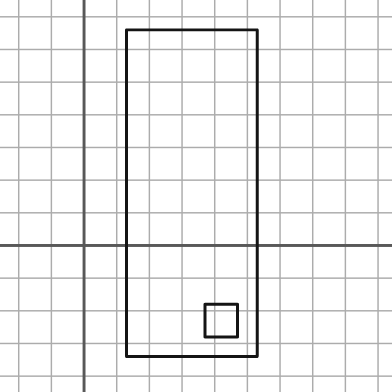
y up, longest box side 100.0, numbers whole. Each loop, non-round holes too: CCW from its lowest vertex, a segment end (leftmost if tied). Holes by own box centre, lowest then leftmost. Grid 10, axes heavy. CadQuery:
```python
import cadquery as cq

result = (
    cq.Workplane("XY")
    .moveTo(13.0, -34.0)
    .lineTo(53.0, -34.0)
    .lineTo(53.0, 66.0)
    .lineTo(13.0, 66.0)
    .close()
    .moveTo(37.0, -28.0)
    .lineTo(47.0, -28.0)
    .lineTo(47.0, -18.0)
    .lineTo(37.0, -18.0)
    .close()
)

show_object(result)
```